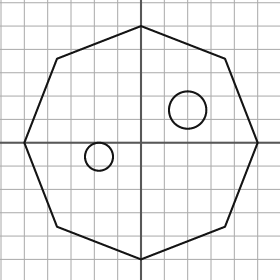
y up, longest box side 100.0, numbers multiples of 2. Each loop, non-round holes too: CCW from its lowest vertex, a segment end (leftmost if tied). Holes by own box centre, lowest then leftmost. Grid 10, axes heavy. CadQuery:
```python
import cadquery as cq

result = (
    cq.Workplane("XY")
    .moveTo(0.0, -50.0)
    .lineTo(36.0, -36.0)
    .lineTo(50.0, 0.0)
    .lineTo(36.0, 36.0)
    .lineTo(0.0, 50.0)
    .lineTo(-36.0, 36.0)
    .lineTo(-50.0, 0.0)
    .lineTo(-36.0, -36.0)
    .close()
    .moveTo(-18.0, -6.0)
    .circle(6.0)
    .moveTo(20.0, 14.0)
    .circle(8.0)
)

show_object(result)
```